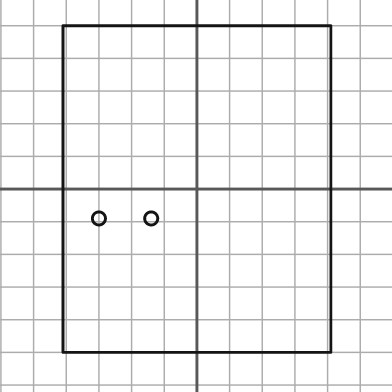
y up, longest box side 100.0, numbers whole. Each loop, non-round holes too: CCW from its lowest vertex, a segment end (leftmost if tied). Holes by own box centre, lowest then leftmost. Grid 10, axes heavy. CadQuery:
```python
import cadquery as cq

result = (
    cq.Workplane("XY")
    .moveTo(-41.0, -50.0)
    .lineTo(41.0, -50.0)
    .lineTo(41.0, 50.0)
    .lineTo(-41.0, 50.0)
    .close()
    .moveTo(-30.0, -9.0)
    .circle(2.0)
    .moveTo(-14.0, -9.0)
    .circle(2.0)
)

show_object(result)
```